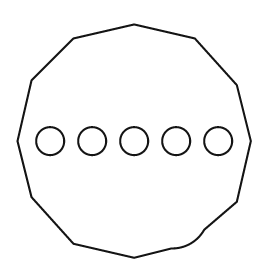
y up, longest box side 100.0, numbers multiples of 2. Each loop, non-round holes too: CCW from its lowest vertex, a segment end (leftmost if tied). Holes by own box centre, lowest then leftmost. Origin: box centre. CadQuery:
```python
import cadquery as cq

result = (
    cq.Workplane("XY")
    .moveTo(0.0, -50.0)
    .lineTo(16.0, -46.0)
    .threePointArc((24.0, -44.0), (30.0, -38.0))
    .lineTo(44.0, -26.0)
    .lineTo(50.0, 0.0)
    .lineTo(44.0, 24.0)
    .lineTo(26.0, 44.0)
    .lineTo(0.0, 50.0)
    .lineTo(-26.0, 44.0)
    .lineTo(-44.0, 26.0)
    .lineTo(-50.0, 0.0)
    .lineTo(-44.0, -24.0)
    .lineTo(-26.0, -44.0)
    .close()
    .moveTo(-36.0, 0.0)
    .circle(6.0)
    .moveTo(-18.0, 0.0)
    .circle(6.0)
    .moveTo(0.0, 0.0)
    .circle(6.0)
    .moveTo(18.0, 0.0)
    .circle(6.0)
    .moveTo(36.0, 0.0)
    .circle(6.0)
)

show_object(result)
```